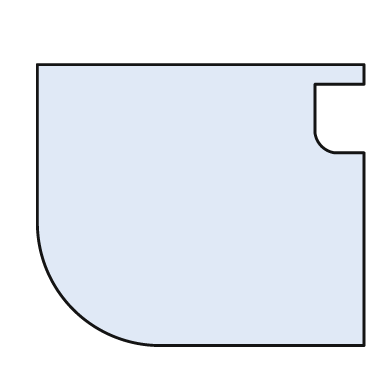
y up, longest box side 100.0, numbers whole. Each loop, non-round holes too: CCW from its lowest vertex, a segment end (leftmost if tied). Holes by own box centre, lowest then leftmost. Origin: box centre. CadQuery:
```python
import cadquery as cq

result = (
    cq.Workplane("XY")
    .moveTo(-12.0, -43.0)
    .lineTo(50.0, -43.0)
    .lineTo(50.0, 16.0)
    .lineTo(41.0, 16.0)
    .threePointArc((37.0, 18.0), (35.0, 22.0))
    .lineTo(35.0, 37.0)
    .lineTo(50.0, 37.0)
    .lineTo(50.0, 43.0)
    .lineTo(-50.0, 43.0)
    .lineTo(-50.0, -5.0)
    .threePointArc((-39.0, -32.0), (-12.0, -43.0))
    .close()
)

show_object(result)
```